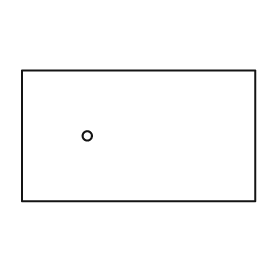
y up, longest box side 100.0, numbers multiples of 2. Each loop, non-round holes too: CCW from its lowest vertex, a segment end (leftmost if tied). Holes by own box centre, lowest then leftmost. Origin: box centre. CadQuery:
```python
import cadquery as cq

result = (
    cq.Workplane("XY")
    .moveTo(-50.0, -28.0)
    .lineTo(50.0, -28.0)
    .lineTo(50.0, 28.0)
    .lineTo(-50.0, 28.0)
    .close()
    .moveTo(-22.0, 0.0)
    .circle(2.0)
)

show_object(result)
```